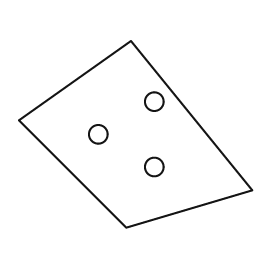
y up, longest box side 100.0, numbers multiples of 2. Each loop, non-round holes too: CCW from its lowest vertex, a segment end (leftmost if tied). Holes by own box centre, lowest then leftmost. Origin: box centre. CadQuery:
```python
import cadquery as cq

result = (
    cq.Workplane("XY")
    .moveTo(-4.0, -40.0)
    .lineTo(50.0, -24.0)
    .lineTo(-2.0, 40.0)
    .lineTo(-50.0, 6.0)
    .close()
    .moveTo(8.0, -14.0)
    .circle(4.0)
    .moveTo(-16.0, 0.0)
    .circle(4.0)
    .moveTo(8.0, 14.0)
    .circle(4.0)
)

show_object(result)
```